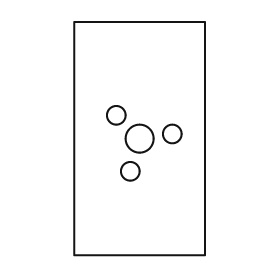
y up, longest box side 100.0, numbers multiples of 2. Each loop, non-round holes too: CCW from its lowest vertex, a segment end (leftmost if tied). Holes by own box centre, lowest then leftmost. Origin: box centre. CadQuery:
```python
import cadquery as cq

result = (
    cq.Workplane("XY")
    .moveTo(-28.0, -50.0)
    .lineTo(28.0, -50.0)
    .lineTo(28.0, 50.0)
    .lineTo(-28.0, 50.0)
    .close()
    .moveTo(-4.0, -14.0)
    .circle(4.0)
    .moveTo(0.0, 0.0)
    .circle(6.0)
    .moveTo(14.0, 2.0)
    .circle(4.0)
    .moveTo(-10.0, 10.0)
    .circle(4.0)
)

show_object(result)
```